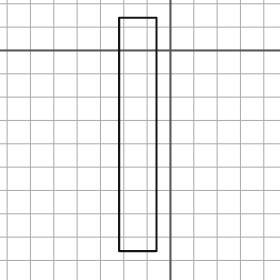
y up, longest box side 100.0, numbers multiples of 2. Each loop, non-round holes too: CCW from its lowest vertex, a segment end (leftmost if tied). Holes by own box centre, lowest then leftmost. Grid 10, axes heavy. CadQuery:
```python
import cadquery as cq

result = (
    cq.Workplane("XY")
    .moveTo(-22.0, -86.0)
    .lineTo(-6.0, -86.0)
    .lineTo(-6.0, 14.0)
    .lineTo(-22.0, 14.0)
    .close()
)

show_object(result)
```